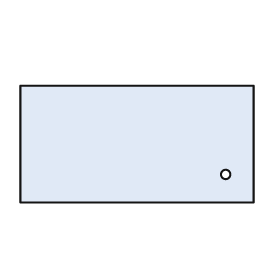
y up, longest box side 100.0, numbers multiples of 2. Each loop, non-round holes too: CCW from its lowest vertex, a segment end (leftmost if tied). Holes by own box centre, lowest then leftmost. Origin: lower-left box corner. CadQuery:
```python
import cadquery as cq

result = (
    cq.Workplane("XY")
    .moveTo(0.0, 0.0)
    .lineTo(100.0, 0.0)
    .lineTo(100.0, 50.0)
    .lineTo(0.0, 50.0)
    .close()
    .moveTo(88.0, 12.0)
    .circle(2.0)
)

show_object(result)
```